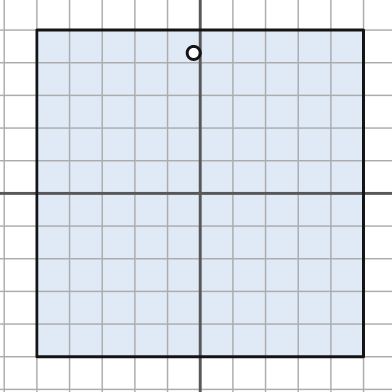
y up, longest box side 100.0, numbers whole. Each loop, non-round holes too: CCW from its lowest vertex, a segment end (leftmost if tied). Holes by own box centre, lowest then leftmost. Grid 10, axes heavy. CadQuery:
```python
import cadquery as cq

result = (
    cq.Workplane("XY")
    .moveTo(-50.0, -50.0)
    .lineTo(50.0, -50.0)
    .lineTo(50.0, 50.0)
    .lineTo(-50.0, 50.0)
    .close()
    .moveTo(-2.0, 43.0)
    .circle(2.0)
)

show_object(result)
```